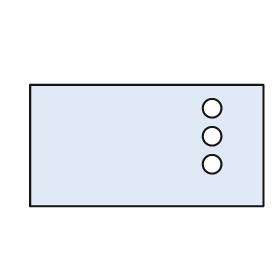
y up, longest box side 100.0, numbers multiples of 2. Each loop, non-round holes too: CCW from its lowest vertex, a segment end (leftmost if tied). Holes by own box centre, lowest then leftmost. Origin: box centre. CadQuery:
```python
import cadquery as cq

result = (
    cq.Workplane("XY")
    .moveTo(-50.0, -26.0)
    .lineTo(50.0, -26.0)
    .lineTo(50.0, 26.0)
    .lineTo(-50.0, 26.0)
    .close()
    .moveTo(28.0, -8.0)
    .circle(4.0)
    .moveTo(28.0, 4.0)
    .circle(4.0)
    .moveTo(28.0, 16.0)
    .circle(4.0)
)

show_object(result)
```